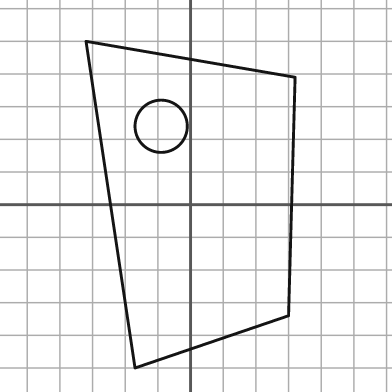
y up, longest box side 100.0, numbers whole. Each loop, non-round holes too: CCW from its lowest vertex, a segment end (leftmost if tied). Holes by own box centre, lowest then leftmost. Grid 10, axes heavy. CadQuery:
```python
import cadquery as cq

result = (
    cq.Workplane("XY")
    .moveTo(-17.0, -50.0)
    .lineTo(30.0, -34.0)
    .lineTo(32.0, 39.0)
    .lineTo(-32.0, 50.0)
    .close()
    .moveTo(-9.0, 24.0)
    .circle(8.0)
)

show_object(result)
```